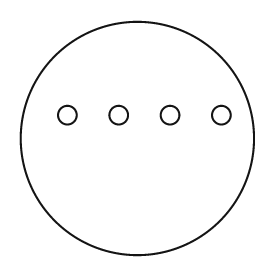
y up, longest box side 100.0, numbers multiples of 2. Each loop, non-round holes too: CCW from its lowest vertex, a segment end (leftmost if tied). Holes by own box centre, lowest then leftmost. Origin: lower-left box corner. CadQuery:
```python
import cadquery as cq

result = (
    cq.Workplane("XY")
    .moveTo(50.0, 50.0)
    .circle(50.0)
    .moveTo(20.0, 60.0)
    .circle(4.0)
    .moveTo(42.0, 60.0)
    .circle(4.0)
    .moveTo(64.0, 60.0)
    .circle(4.0)
    .moveTo(86.0, 60.0)
    .circle(4.0)
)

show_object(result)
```